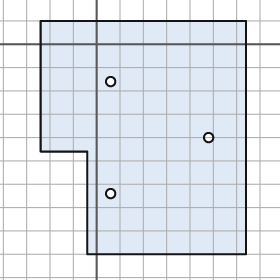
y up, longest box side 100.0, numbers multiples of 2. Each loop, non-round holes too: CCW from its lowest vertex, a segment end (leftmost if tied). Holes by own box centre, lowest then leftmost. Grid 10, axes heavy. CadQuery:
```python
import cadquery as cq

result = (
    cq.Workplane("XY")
    .moveTo(-4.0, -90.0)
    .lineTo(64.0, -90.0)
    .lineTo(64.0, 10.0)
    .lineTo(-24.0, 10.0)
    .lineTo(-24.0, -46.0)
    .lineTo(-4.0, -46.0)
    .close()
    .moveTo(6.0, -64.0)
    .circle(2.0)
    .moveTo(48.0, -40.0)
    .circle(2.0)
    .moveTo(6.0, -16.0)
    .circle(2.0)
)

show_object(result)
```